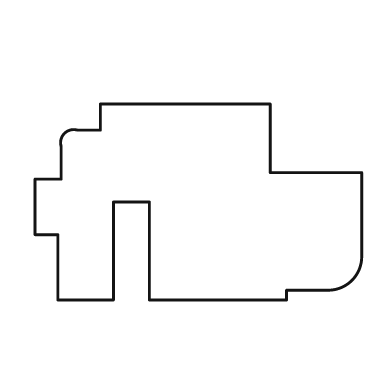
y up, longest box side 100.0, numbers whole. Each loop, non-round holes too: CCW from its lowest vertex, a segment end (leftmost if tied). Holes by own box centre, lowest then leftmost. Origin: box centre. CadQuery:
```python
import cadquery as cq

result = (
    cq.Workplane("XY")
    .moveTo(-43.0, -30.0)
    .lineTo(-26.0, -30.0)
    .lineTo(-26.0, 0.0)
    .lineTo(-15.0, 0.0)
    .lineTo(-15.0, -30.0)
    .lineTo(27.0, -30.0)
    .lineTo(27.0, -27.0)
    .lineTo(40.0, -27.0)
    .threePointArc((47.0, -24.0), (50.0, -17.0))
    .lineTo(50.0, 9.0)
    .lineTo(22.0, 9.0)
    .lineTo(22.0, 30.0)
    .lineTo(-30.0, 30.0)
    .lineTo(-30.0, 22.0)
    .lineTo(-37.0, 22.0)
    .threePointArc((-41.0, 21.0), (-42.0, 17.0))
    .lineTo(-42.0, 7.0)
    .lineTo(-50.0, 7.0)
    .lineTo(-50.0, -10.0)
    .lineTo(-43.0, -10.0)
    .close()
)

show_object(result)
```